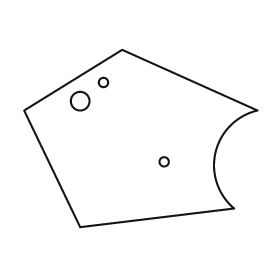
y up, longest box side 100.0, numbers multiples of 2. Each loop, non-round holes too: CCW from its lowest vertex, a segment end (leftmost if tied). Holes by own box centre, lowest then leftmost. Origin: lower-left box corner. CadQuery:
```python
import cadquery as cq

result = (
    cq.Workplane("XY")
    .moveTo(24.0, 0.0)
    .lineTo(90.0, 8.0)
    .threePointArc((82.0, 32.0), (100.0, 50.0))
    .lineTo(42.0, 76.0)
    .lineTo(0.0, 50.0)
    .close()
    .moveTo(60.0, 28.0)
    .circle(2.0)
    .moveTo(24.0, 54.0)
    .circle(4.0)
    .moveTo(34.0, 62.0)
    .circle(2.0)
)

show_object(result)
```